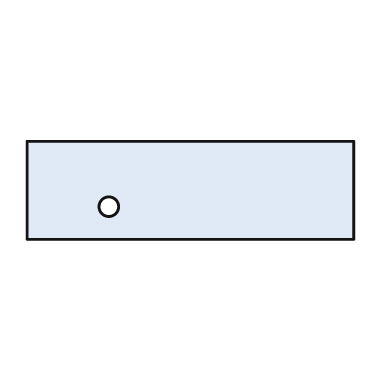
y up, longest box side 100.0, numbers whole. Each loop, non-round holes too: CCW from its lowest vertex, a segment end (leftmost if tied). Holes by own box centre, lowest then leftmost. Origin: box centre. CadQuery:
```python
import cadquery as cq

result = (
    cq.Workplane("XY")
    .moveTo(-50.0, -15.0)
    .lineTo(50.0, -15.0)
    .lineTo(50.0, 15.0)
    .lineTo(-50.0, 15.0)
    .close()
    .moveTo(-25.0, -5.0)
    .circle(3.0)
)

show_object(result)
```